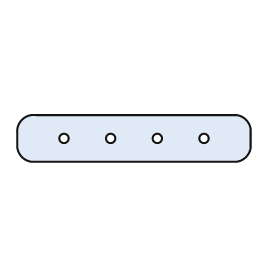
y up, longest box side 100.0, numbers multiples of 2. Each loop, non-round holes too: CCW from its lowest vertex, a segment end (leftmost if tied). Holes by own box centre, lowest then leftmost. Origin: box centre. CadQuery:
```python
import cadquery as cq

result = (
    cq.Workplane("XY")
    .moveTo(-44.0, -10.0)
    .lineTo(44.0, -10.0)
    .threePointArc((48.0, -8.0), (50.0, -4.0))
    .lineTo(50.0, 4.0)
    .threePointArc((48.0, 8.0), (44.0, 10.0))
    .lineTo(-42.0, 10.0)
    .threePointArc((-48.0, 8.0), (-50.0, 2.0))
    .lineTo(-50.0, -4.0)
    .threePointArc((-48.0, -8.0), (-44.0, -10.0))
    .close()
    .moveTo(-30.0, 0.0)
    .circle(2.0)
    .moveTo(-10.0, 0.0)
    .circle(2.0)
    .moveTo(10.0, 0.0)
    .circle(2.0)
    .moveTo(30.0, 0.0)
    .circle(2.0)
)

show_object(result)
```